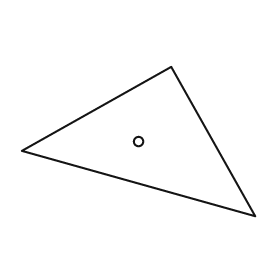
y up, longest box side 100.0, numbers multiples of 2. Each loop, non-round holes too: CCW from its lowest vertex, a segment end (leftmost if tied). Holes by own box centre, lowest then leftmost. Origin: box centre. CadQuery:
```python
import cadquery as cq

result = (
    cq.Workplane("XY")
    .moveTo(50.0, -32.0)
    .lineTo(14.0, 32.0)
    .lineTo(-50.0, -4.0)
    .close()
    .moveTo(0.0, 0.0)
    .circle(2.0)
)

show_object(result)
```